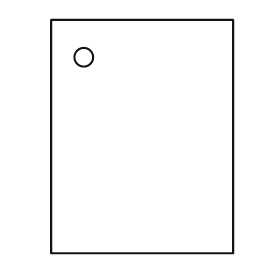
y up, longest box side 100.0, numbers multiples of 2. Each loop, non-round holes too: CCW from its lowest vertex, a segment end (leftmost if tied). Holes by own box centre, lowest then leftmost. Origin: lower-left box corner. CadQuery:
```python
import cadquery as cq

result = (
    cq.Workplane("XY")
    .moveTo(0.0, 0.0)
    .lineTo(78.0, 0.0)
    .lineTo(78.0, 100.0)
    .lineTo(0.0, 100.0)
    .close()
    .moveTo(14.0, 84.0)
    .circle(4.0)
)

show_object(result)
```